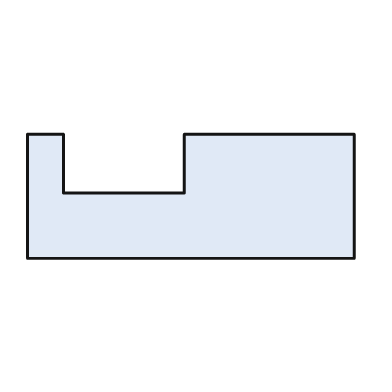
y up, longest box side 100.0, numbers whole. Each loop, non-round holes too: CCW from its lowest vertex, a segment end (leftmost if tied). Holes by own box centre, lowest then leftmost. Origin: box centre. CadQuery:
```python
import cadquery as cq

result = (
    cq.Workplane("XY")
    .moveTo(-50.0, -19.0)
    .lineTo(50.0, -19.0)
    .lineTo(50.0, 19.0)
    .lineTo(-2.0, 19.0)
    .lineTo(-2.0, 1.0)
    .lineTo(-39.0, 1.0)
    .lineTo(-39.0, 19.0)
    .lineTo(-50.0, 19.0)
    .close()
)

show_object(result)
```